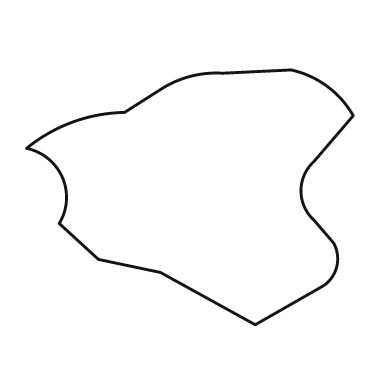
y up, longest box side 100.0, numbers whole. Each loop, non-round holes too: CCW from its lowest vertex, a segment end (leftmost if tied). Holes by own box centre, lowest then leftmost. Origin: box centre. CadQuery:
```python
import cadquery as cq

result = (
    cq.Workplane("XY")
    .moveTo(20.0, -39.0)
    .lineTo(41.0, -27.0)
    .threePointArc((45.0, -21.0), (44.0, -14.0))
    .lineTo(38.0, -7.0)
    .threePointArc((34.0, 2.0), (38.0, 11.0))
    .lineTo(50.0, 25.0)
    .threePointArc((42.0, 34.0), (31.0, 39.0))
    .lineTo(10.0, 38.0)
    .threePointArc((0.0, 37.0), (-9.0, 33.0))
    .lineTo(-20.0, 26.0)
    .threePointArc((-36.0, 23.0), (-50.0, 15.0))
    .threePointArc((-39.0, 6.0), (-40.0, -8.0))
    .lineTo(-28.0, -19.0)
    .lineTo(-9.0, -23.0)
    .close()
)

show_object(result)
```